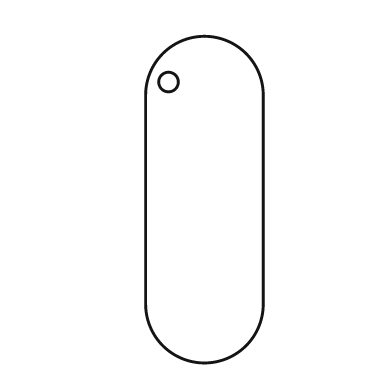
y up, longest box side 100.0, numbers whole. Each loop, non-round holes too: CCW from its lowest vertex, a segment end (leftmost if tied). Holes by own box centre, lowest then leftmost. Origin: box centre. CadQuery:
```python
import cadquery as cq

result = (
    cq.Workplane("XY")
    .moveTo(-18.0, -32.0)
    .threePointArc((0.0, -50.0), (18.0, -32.0))
    .lineTo(18.0, 32.0)
    .threePointArc((0.0, 50.0), (-18.0, 32.0))
    .close()
    .moveTo(-11.0, 36.0)
    .circle(3.0)
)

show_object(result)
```